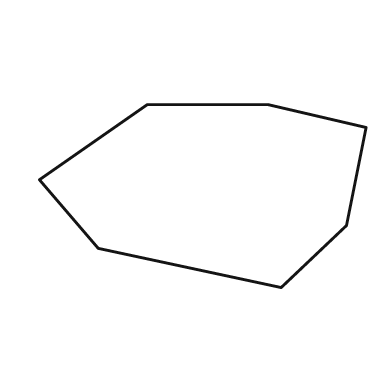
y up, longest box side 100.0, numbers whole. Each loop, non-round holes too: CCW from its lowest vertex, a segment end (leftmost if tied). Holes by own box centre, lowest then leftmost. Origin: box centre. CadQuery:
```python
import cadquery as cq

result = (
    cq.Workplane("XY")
    .moveTo(24.0, -28.0)
    .lineTo(44.0, -9.0)
    .lineTo(50.0, 21.0)
    .lineTo(20.0, 28.0)
    .lineTo(-17.0, 28.0)
    .lineTo(-50.0, 5.0)
    .lineTo(-32.0, -16.0)
    .close()
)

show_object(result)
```